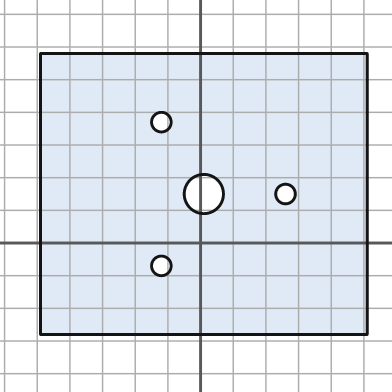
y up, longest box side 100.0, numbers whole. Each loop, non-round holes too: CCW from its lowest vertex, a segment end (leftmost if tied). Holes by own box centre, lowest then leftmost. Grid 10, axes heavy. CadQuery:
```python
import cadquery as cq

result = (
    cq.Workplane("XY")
    .moveTo(-49.0, -28.0)
    .lineTo(51.0, -28.0)
    .lineTo(51.0, 58.0)
    .lineTo(-49.0, 58.0)
    .close()
    .moveTo(-12.0, -7.0)
    .circle(3.0)
    .moveTo(1.0, 15.0)
    .circle(6.0)
    .moveTo(26.0, 15.0)
    .circle(3.0)
    .moveTo(-12.0, 37.0)
    .circle(3.0)
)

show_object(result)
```